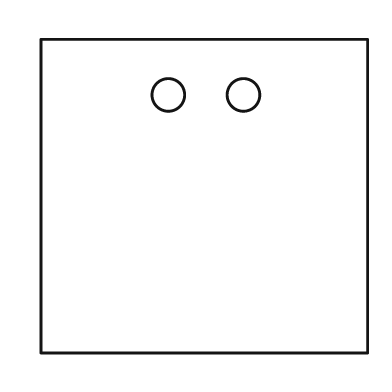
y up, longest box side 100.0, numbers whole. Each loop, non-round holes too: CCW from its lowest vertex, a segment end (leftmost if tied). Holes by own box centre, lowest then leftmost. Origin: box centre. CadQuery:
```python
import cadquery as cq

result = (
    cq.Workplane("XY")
    .moveTo(-50.0, -48.0)
    .lineTo(50.0, -48.0)
    .lineTo(50.0, 48.0)
    .lineTo(-50.0, 48.0)
    .close()
    .moveTo(-11.0, 31.0)
    .circle(5.0)
    .moveTo(12.0, 31.0)
    .circle(5.0)
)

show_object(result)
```